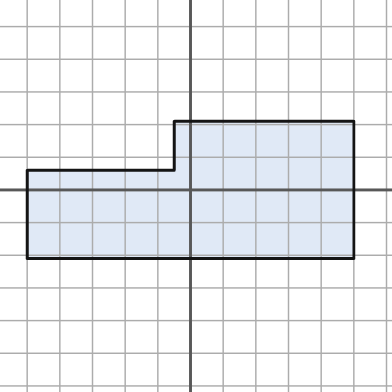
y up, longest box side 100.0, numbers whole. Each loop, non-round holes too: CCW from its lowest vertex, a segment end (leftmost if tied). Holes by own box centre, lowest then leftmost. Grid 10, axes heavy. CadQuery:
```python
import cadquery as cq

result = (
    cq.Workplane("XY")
    .moveTo(-50.0, -21.0)
    .lineTo(50.0, -21.0)
    .lineTo(50.0, 21.0)
    .lineTo(-5.0, 21.0)
    .lineTo(-5.0, 6.0)
    .lineTo(-50.0, 6.0)
    .close()
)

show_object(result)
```